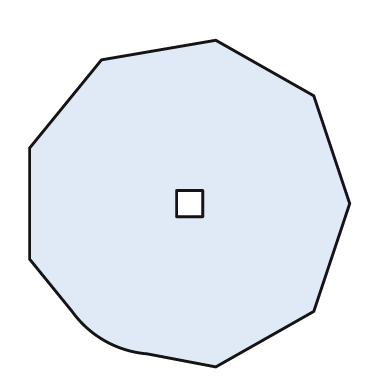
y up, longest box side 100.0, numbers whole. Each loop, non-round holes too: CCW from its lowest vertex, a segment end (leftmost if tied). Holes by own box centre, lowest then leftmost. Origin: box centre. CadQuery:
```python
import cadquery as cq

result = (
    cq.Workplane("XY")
    .moveTo(8.0, -50.0)
    .lineTo(38.0, -33.0)
    .lineTo(49.0, 0.0)
    .lineTo(38.0, 33.0)
    .lineTo(8.0, 50.0)
    .lineTo(-27.0, 44.0)
    .lineTo(-49.0, 17.0)
    .lineTo(-49.0, -17.0)
    .lineTo(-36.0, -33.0)
    .threePointArc((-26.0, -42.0), (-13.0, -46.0))
    .close()
    .moveTo(-4.0, -4.0)
    .lineTo(4.0, -4.0)
    .lineTo(4.0, 4.0)
    .lineTo(-4.0, 4.0)
    .close()
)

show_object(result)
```